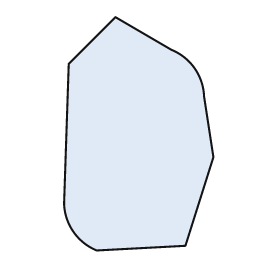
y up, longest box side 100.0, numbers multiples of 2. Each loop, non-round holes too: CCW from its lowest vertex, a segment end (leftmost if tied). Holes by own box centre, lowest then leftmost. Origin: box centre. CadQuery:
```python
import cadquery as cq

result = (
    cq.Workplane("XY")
    .moveTo(-18.0, -50.0)
    .lineTo(20.0, -48.0)
    .lineTo(32.0, -10.0)
    .lineTo(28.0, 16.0)
    .threePointArc((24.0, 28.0), (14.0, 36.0))
    .lineTo(-10.0, 50.0)
    .lineTo(-30.0, 30.0)
    .lineTo(-32.0, -30.0)
    .threePointArc((-28.0, -42.0), (-18.0, -50.0))
    .close()
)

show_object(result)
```